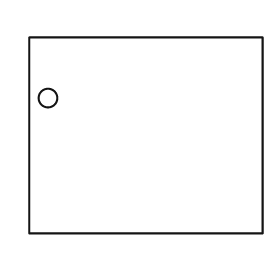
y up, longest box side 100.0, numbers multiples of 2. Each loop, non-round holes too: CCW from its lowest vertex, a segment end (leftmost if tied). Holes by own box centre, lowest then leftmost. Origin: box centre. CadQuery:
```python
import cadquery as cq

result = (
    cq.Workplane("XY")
    .moveTo(-50.0, -42.0)
    .lineTo(50.0, -42.0)
    .lineTo(50.0, 42.0)
    .lineTo(-50.0, 42.0)
    .close()
    .moveTo(-42.0, 16.0)
    .circle(4.0)
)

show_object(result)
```